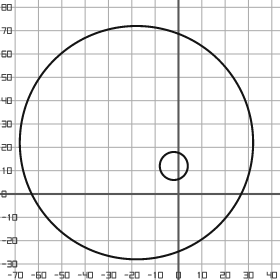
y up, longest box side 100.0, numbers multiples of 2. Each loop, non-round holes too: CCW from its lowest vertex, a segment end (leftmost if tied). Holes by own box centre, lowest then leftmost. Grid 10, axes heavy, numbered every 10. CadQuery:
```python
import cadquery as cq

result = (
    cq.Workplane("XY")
    .moveTo(-18.0, 22.0)
    .circle(50.0)
    .moveTo(-2.0, 12.0)
    .circle(6.0)
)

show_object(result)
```